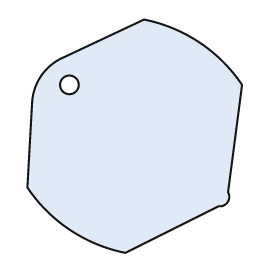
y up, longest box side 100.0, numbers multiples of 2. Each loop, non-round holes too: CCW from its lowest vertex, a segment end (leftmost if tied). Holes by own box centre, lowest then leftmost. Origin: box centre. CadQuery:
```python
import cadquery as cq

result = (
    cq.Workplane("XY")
    .moveTo(-4.0, -50.0)
    .lineTo(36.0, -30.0)
    .threePointArc((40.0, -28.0), (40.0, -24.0))
    .lineTo(46.0, 22.0)
    .threePointArc((28.0, 40.0), (4.0, 50.0))
    .lineTo(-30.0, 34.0)
    .threePointArc((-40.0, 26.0), (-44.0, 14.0))
    .lineTo(-46.0, -22.0)
    .threePointArc((-28.0, -40.0), (-4.0, -50.0))
    .close()
    .moveTo(-28.0, 22.0)
    .circle(4.0)
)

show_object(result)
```